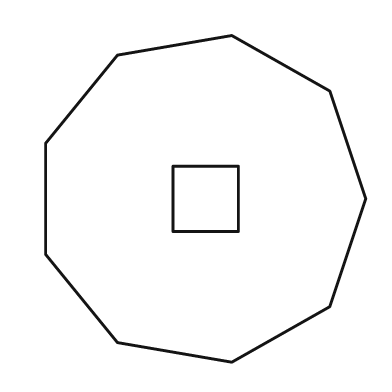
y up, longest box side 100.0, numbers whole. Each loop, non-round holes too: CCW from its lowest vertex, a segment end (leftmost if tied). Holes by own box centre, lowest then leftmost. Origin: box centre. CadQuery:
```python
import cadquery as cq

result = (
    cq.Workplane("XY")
    .moveTo(8.0, -50.0)
    .lineTo(38.0, -33.0)
    .lineTo(49.0, 0.0)
    .lineTo(38.0, 33.0)
    .lineTo(8.0, 50.0)
    .lineTo(-27.0, 44.0)
    .lineTo(-49.0, 17.0)
    .lineTo(-49.0, -17.0)
    .lineTo(-27.0, -44.0)
    .close()
    .moveTo(-10.0, -10.0)
    .lineTo(10.0, -10.0)
    .lineTo(10.0, 10.0)
    .lineTo(-10.0, 10.0)
    .close()
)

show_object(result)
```